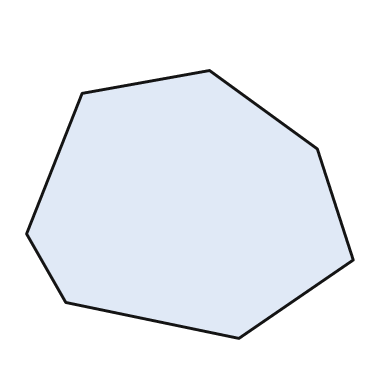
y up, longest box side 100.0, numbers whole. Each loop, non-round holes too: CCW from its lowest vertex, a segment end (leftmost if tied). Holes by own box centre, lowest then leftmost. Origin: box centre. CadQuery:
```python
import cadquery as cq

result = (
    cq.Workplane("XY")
    .moveTo(15.0, -41.0)
    .lineTo(50.0, -17.0)
    .lineTo(39.0, 17.0)
    .lineTo(6.0, 41.0)
    .lineTo(-33.0, 34.0)
    .lineTo(-50.0, -9.0)
    .lineTo(-38.0, -30.0)
    .close()
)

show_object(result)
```